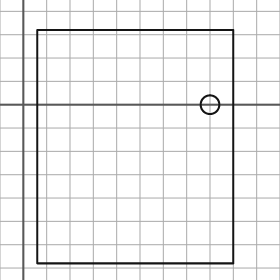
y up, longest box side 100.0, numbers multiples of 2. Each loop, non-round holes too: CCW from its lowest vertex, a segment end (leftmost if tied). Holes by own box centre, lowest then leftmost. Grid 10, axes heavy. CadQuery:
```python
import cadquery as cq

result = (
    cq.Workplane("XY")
    .moveTo(6.0, -68.0)
    .lineTo(90.0, -68.0)
    .lineTo(90.0, 32.0)
    .lineTo(6.0, 32.0)
    .close()
    .moveTo(80.0, 0.0)
    .circle(4.0)
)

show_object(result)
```